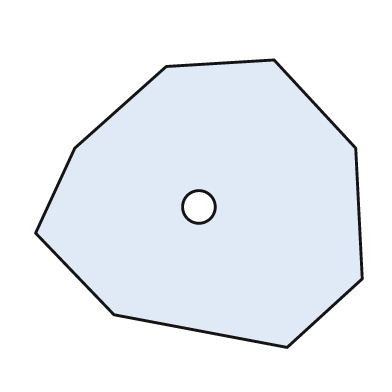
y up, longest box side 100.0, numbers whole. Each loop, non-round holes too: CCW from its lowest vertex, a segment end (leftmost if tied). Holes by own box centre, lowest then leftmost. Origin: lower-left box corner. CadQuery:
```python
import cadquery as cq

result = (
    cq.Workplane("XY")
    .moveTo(77.0, 0.0)
    .lineTo(100.0, 21.0)
    .lineTo(98.0, 61.0)
    .lineTo(73.0, 88.0)
    .lineTo(40.0, 86.0)
    .lineTo(12.0, 61.0)
    .lineTo(0.0, 35.0)
    .lineTo(24.0, 10.0)
    .close()
    .moveTo(50.0, 43.0)
    .circle(5.0)
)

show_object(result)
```